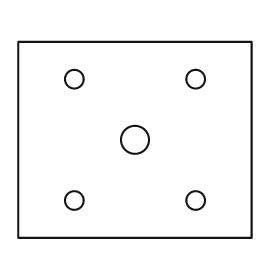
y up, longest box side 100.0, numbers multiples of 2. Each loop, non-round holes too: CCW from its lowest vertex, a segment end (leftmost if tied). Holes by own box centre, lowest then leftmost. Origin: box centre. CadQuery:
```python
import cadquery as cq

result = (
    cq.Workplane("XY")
    .moveTo(-50.0, -42.0)
    .lineTo(50.0, -42.0)
    .lineTo(50.0, 42.0)
    .lineTo(-50.0, 42.0)
    .close()
    .moveTo(-26.0, -26.0)
    .circle(4.0)
    .moveTo(26.0, -26.0)
    .circle(4.0)
    .moveTo(0.0, 0.0)
    .circle(6.0)
    .moveTo(-26.0, 26.0)
    .circle(4.0)
    .moveTo(26.0, 26.0)
    .circle(4.0)
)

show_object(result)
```